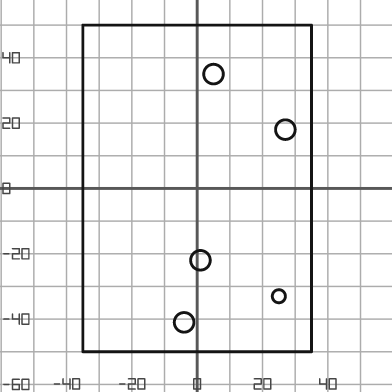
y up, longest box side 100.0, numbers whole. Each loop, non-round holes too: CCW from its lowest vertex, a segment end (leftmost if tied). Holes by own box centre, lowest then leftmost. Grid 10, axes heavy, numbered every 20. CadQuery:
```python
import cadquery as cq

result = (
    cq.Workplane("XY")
    .moveTo(-35.0, -50.0)
    .lineTo(35.0, -50.0)
    .lineTo(35.0, 50.0)
    .lineTo(-35.0, 50.0)
    .close()
    .moveTo(-4.0, -41.0)
    .circle(3.0)
    .moveTo(25.0, -33.0)
    .circle(2.0)
    .moveTo(1.0, -22.0)
    .circle(3.0)
    .moveTo(27.0, 18.0)
    .circle(3.0)
    .moveTo(5.0, 35.0)
    .circle(3.0)
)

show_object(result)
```